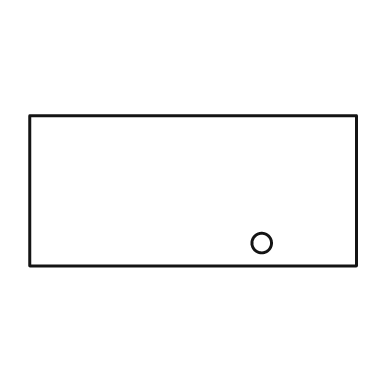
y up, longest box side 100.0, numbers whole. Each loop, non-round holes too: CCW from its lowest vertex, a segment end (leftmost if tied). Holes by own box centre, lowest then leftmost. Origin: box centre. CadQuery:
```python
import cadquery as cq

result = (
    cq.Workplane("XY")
    .moveTo(-50.0, -23.0)
    .lineTo(50.0, -23.0)
    .lineTo(50.0, 23.0)
    .lineTo(-50.0, 23.0)
    .close()
    .moveTo(21.0, -16.0)
    .circle(3.0)
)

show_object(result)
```